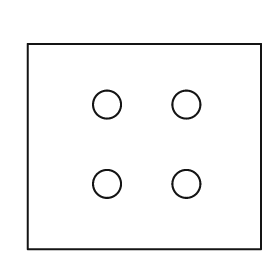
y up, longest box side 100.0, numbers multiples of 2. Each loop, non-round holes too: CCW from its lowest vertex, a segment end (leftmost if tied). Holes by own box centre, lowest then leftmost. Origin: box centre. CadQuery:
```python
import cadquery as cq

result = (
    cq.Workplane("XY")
    .moveTo(-50.0, -44.0)
    .lineTo(50.0, -44.0)
    .lineTo(50.0, 44.0)
    .lineTo(-50.0, 44.0)
    .close()
    .moveTo(-16.0, -16.0)
    .circle(6.0)
    .moveTo(18.0, -16.0)
    .circle(6.0)
    .moveTo(-16.0, 18.0)
    .circle(6.0)
    .moveTo(18.0, 18.0)
    .circle(6.0)
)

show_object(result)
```